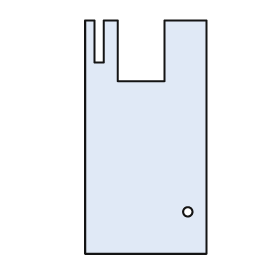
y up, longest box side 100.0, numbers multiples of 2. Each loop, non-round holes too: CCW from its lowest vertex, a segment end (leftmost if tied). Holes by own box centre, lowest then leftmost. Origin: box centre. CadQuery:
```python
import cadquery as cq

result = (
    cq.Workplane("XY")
    .moveTo(-26.0, -50.0)
    .lineTo(26.0, -50.0)
    .lineTo(26.0, 50.0)
    .lineTo(8.0, 50.0)
    .lineTo(8.0, 24.0)
    .lineTo(-12.0, 24.0)
    .lineTo(-12.0, 50.0)
    .lineTo(-18.0, 50.0)
    .lineTo(-18.0, 32.0)
    .lineTo(-22.0, 32.0)
    .lineTo(-22.0, 50.0)
    .lineTo(-26.0, 50.0)
    .close()
    .moveTo(18.0, -32.0)
    .circle(2.0)
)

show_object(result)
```